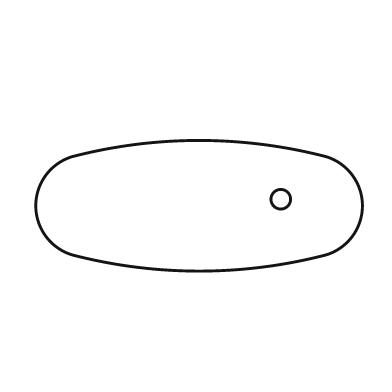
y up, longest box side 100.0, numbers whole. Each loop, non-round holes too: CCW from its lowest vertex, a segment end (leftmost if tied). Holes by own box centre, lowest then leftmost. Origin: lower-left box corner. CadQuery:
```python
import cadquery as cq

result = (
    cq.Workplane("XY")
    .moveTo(11.0, 5.0)
    .threePointArc((50.0, 0.0), (89.0, 5.0))
    .threePointArc((100.0, 20.0), (89.0, 35.0))
    .threePointArc((50.0, 40.0), (11.0, 35.0))
    .threePointArc((0.0, 20.0), (11.0, 5.0))
    .close()
    .moveTo(75.0, 22.0)
    .circle(3.0)
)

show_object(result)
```